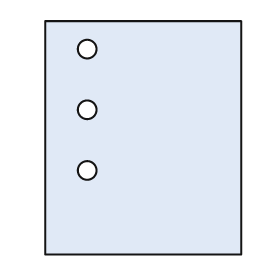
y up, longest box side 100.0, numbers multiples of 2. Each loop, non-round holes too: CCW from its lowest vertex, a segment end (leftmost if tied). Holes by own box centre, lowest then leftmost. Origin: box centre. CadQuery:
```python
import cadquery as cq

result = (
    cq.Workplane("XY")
    .moveTo(-42.0, -50.0)
    .lineTo(42.0, -50.0)
    .lineTo(42.0, 50.0)
    .lineTo(-42.0, 50.0)
    .close()
    .moveTo(-24.0, -14.0)
    .circle(4.0)
    .moveTo(-24.0, 12.0)
    .circle(4.0)
    .moveTo(-24.0, 38.0)
    .circle(4.0)
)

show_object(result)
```